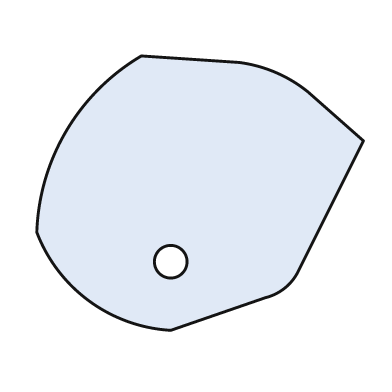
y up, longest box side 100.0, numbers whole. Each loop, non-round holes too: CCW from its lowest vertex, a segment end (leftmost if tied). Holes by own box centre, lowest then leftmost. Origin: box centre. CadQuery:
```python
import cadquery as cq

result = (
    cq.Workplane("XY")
    .moveTo(-9.0, -42.0)
    .lineTo(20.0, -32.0)
    .threePointArc((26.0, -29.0), (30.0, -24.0))
    .lineTo(50.0, 16.0)
    .lineTo(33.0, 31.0)
    .threePointArc((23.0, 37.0), (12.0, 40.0))
    .lineTo(-18.0, 42.0)
    .threePointArc((-41.0, 19.0), (-50.0, -12.0))
    .threePointArc((-34.0, -33.0), (-9.0, -42.0))
    .close()
    .moveTo(-9.0, -21.0)
    .circle(5.0)
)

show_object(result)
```